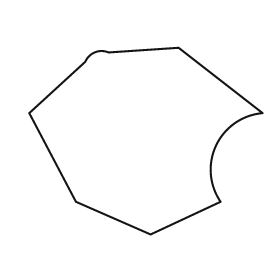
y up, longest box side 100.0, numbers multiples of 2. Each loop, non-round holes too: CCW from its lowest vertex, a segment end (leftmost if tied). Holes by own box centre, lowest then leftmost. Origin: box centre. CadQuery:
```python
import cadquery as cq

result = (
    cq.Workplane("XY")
    .moveTo(2.0, -40.0)
    .lineTo(32.0, -26.0)
    .threePointArc((30.0, -2.0), (50.0, 12.0))
    .lineTo(14.0, 40.0)
    .lineTo(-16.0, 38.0)
    .threePointArc((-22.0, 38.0), (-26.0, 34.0))
    .lineTo(-50.0, 12.0)
    .lineTo(-30.0, -26.0)
    .close()
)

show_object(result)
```